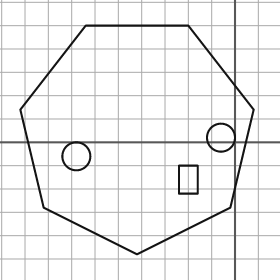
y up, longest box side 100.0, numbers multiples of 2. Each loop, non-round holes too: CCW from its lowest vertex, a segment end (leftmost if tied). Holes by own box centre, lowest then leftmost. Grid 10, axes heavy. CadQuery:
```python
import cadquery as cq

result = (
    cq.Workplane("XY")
    .moveTo(-42.0, -48.0)
    .lineTo(-2.0, -28.0)
    .lineTo(8.0, 14.0)
    .lineTo(-20.0, 50.0)
    .lineTo(-64.0, 50.0)
    .lineTo(-92.0, 14.0)
    .lineTo(-82.0, -28.0)
    .close()
    .moveTo(-24.0, -22.0)
    .lineTo(-16.0, -22.0)
    .lineTo(-16.0, -10.0)
    .lineTo(-24.0, -10.0)
    .close()
    .moveTo(-68.0, -6.0)
    .circle(6.0)
    .moveTo(-6.0, 2.0)
    .circle(6.0)
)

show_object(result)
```